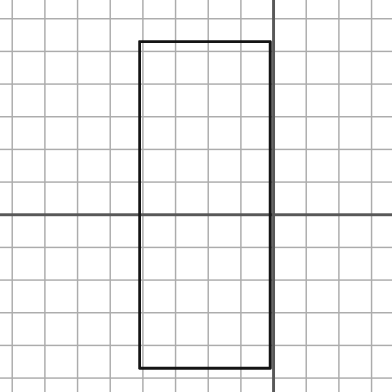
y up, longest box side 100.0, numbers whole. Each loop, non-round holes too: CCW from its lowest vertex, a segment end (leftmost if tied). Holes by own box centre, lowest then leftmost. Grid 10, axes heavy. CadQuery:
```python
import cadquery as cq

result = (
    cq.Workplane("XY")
    .moveTo(-41.0, -47.0)
    .lineTo(-1.0, -47.0)
    .lineTo(-1.0, 53.0)
    .lineTo(-41.0, 53.0)
    .close()
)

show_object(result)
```